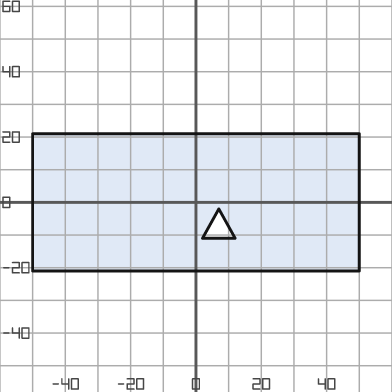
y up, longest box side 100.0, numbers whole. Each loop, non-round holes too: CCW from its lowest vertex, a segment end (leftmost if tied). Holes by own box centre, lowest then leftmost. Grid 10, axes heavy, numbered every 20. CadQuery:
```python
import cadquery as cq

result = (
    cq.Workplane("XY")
    .moveTo(-50.0, -21.0)
    .lineTo(50.0, -21.0)
    .lineTo(50.0, 21.0)
    .lineTo(-50.0, 21.0)
    .close()
    .moveTo(2.0, -11.0)
    .lineTo(12.0, -11.0)
    .lineTo(7.0, -2.0)
    .close()
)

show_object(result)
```